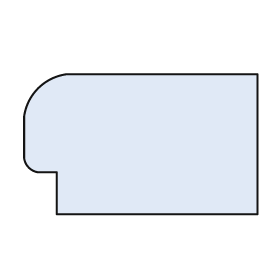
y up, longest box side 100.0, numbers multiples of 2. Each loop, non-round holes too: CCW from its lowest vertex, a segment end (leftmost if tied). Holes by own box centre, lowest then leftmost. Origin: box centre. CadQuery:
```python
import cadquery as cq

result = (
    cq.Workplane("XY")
    .moveTo(-36.0, -30.0)
    .lineTo(50.0, -30.0)
    .lineTo(50.0, 30.0)
    .lineTo(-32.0, 30.0)
    .threePointArc((-44.0, 24.0), (-50.0, 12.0))
    .lineTo(-50.0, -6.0)
    .threePointArc((-48.0, -10.0), (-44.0, -12.0))
    .lineTo(-36.0, -12.0)
    .close()
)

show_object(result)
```